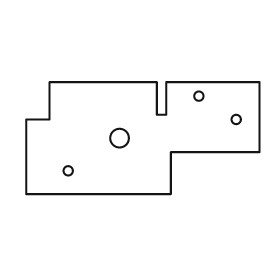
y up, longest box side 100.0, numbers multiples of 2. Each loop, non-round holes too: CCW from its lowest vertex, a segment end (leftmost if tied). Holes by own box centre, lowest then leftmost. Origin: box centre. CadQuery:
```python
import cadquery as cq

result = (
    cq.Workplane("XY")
    .moveTo(-50.0, -24.0)
    .lineTo(12.0, -24.0)
    .lineTo(12.0, -6.0)
    .lineTo(50.0, -6.0)
    .lineTo(50.0, 24.0)
    .lineTo(10.0, 24.0)
    .lineTo(10.0, 10.0)
    .lineTo(6.0, 10.0)
    .lineTo(6.0, 24.0)
    .lineTo(-40.0, 24.0)
    .lineTo(-40.0, 8.0)
    .lineTo(-50.0, 8.0)
    .close()
    .moveTo(-32.0, -14.0)
    .circle(2.0)
    .moveTo(-10.0, 0.0)
    .circle(4.0)
    .moveTo(40.0, 8.0)
    .circle(2.0)
    .moveTo(24.0, 18.0)
    .circle(2.0)
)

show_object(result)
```